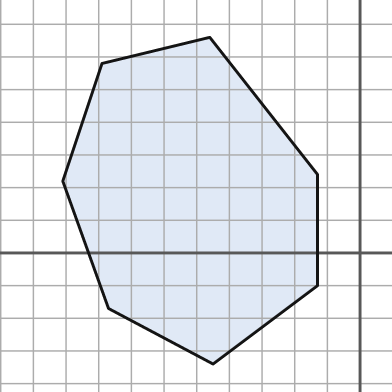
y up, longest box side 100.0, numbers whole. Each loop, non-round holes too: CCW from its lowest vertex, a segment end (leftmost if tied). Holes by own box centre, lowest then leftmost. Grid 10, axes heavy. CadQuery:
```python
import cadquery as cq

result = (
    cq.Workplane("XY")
    .moveTo(-45.0, -34.0)
    .lineTo(-13.0, -10.0)
    .lineTo(-13.0, 24.0)
    .lineTo(-46.0, 66.0)
    .lineTo(-79.0, 58.0)
    .lineTo(-91.0, 22.0)
    .lineTo(-77.0, -17.0)
    .close()
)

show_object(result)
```